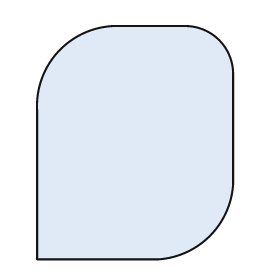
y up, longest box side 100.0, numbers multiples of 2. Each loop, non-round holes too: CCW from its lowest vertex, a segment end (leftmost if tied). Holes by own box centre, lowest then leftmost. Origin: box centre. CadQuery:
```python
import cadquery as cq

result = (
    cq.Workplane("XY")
    .moveTo(-42.0, -50.0)
    .lineTo(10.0, -50.0)
    .threePointArc((32.0, -40.0), (42.0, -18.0))
    .lineTo(42.0, 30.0)
    .threePointArc((36.0, 44.0), (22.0, 50.0))
    .lineTo(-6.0, 50.0)
    .threePointArc((-32.0, 40.0), (-42.0, 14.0))
    .close()
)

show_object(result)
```